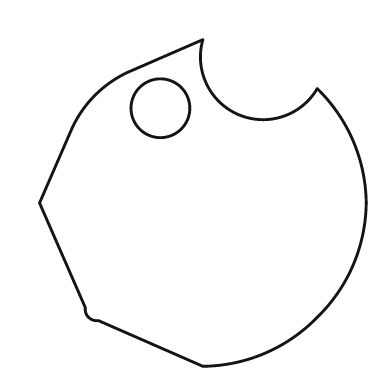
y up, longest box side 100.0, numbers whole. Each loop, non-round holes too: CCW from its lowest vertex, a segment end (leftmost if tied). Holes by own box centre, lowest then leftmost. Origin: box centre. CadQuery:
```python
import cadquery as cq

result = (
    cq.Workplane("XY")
    .moveTo(0.0, -50.0)
    .threePointArc((19.0, -46.0), (35.0, -35.0))
    .threePointArc((46.0, -19.0), (50.0, 0.0))
    .threePointArc((46.0, 19.0), (35.0, 35.0))
    .threePointArc((11.0, 27.0), (0.0, 50.0))
    .lineTo(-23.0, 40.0)
    .threePointArc((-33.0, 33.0), (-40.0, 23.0))
    .lineTo(-50.0, 0.0)
    .lineTo(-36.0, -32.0)
    .threePointArc((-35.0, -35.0), (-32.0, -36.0))
    .close()
    .moveTo(-13.0, 29.0)
    .circle(9.0)
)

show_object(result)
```